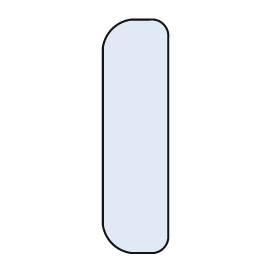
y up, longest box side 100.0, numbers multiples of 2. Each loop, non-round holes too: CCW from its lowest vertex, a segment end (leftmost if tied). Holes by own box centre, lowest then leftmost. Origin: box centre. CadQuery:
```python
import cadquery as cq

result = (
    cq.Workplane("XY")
    .moveTo(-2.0, -50.0)
    .lineTo(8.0, -50.0)
    .threePointArc((12.0, -48.0), (14.0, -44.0))
    .lineTo(14.0, 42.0)
    .threePointArc((12.0, 48.0), (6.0, 50.0))
    .lineTo(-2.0, 50.0)
    .threePointArc((-10.0, 46.0), (-14.0, 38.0))
    .lineTo(-14.0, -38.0)
    .threePointArc((-10.0, -46.0), (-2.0, -50.0))
    .close()
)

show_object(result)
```